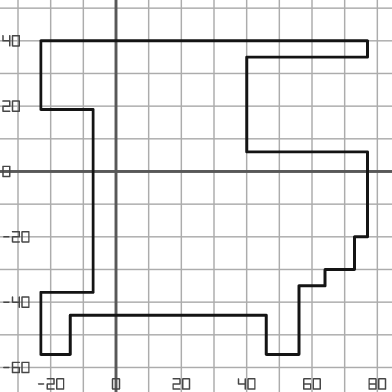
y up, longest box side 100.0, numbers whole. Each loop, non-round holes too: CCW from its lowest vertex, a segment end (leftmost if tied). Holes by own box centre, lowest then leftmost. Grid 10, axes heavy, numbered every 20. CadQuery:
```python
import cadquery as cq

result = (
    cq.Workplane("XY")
    .moveTo(-23.0, -56.0)
    .lineTo(-14.0, -56.0)
    .lineTo(-14.0, -44.0)
    .lineTo(46.0, -44.0)
    .lineTo(46.0, -56.0)
    .lineTo(56.0, -56.0)
    .lineTo(56.0, -35.0)
    .lineTo(64.0, -35.0)
    .lineTo(64.0, -30.0)
    .lineTo(73.0, -30.0)
    .lineTo(73.0, -20.0)
    .lineTo(77.0, -20.0)
    .lineTo(77.0, 6.0)
    .lineTo(40.0, 6.0)
    .lineTo(40.0, 35.0)
    .lineTo(77.0, 35.0)
    .lineTo(77.0, 40.0)
    .lineTo(-23.0, 40.0)
    .lineTo(-23.0, 19.0)
    .lineTo(-7.0, 19.0)
    .lineTo(-7.0, -37.0)
    .lineTo(-23.0, -37.0)
    .close()
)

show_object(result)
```